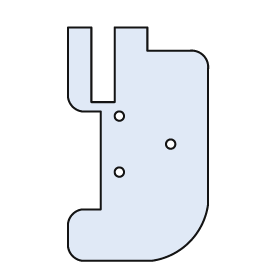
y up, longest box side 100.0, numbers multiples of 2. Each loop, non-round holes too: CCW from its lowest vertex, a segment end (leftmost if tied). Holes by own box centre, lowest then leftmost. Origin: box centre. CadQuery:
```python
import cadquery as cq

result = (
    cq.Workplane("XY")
    .moveTo(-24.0, -50.0)
    .lineTo(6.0, -50.0)
    .threePointArc((22.0, -42.0), (30.0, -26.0))
    .lineTo(30.0, 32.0)
    .threePointArc((28.0, 38.0), (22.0, 40.0))
    .lineTo(4.0, 40.0)
    .lineTo(4.0, 50.0)
    .lineTo(-10.0, 50.0)
    .lineTo(-10.0, 18.0)
    .lineTo(-20.0, 18.0)
    .lineTo(-20.0, 50.0)
    .lineTo(-30.0, 50.0)
    .lineTo(-30.0, 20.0)
    .threePointArc((-28.0, 16.0), (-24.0, 14.0))
    .lineTo(-16.0, 14.0)
    .lineTo(-16.0, -28.0)
    .lineTo(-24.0, -28.0)
    .threePointArc((-28.0, -30.0), (-30.0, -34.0))
    .lineTo(-30.0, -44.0)
    .threePointArc((-28.0, -48.0), (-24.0, -50.0))
    .close()
    .moveTo(-8.0, -12.0)
    .circle(2.0)
    .moveTo(14.0, 0.0)
    .circle(2.0)
    .moveTo(-8.0, 12.0)
    .circle(2.0)
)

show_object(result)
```